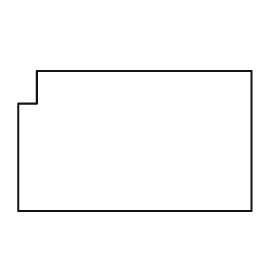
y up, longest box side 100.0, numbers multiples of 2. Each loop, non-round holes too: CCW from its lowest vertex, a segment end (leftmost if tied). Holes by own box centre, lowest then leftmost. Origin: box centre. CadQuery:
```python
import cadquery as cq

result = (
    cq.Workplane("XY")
    .moveTo(-50.0, -30.0)
    .lineTo(50.0, -30.0)
    .lineTo(50.0, 30.0)
    .lineTo(-42.0, 30.0)
    .lineTo(-42.0, 16.0)
    .lineTo(-50.0, 16.0)
    .close()
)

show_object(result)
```